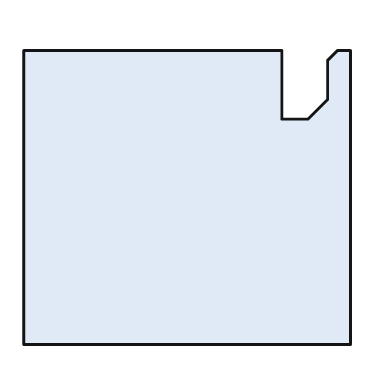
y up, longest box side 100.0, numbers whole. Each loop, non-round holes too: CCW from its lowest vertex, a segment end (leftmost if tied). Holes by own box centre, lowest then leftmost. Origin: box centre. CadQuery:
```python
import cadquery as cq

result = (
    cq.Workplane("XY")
    .moveTo(-50.0, -45.0)
    .lineTo(50.0, -45.0)
    .lineTo(50.0, 45.0)
    .lineTo(46.0, 45.0)
    .lineTo(43.0, 42.0)
    .lineTo(43.0, 30.0)
    .lineTo(37.0, 24.0)
    .lineTo(29.0, 24.0)
    .lineTo(29.0, 45.0)
    .lineTo(-50.0, 45.0)
    .close()
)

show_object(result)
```